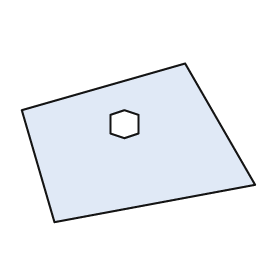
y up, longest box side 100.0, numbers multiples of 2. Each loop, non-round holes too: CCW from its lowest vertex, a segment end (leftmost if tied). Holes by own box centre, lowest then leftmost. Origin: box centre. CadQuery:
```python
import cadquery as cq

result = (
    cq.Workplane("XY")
    .moveTo(-36.0, -34.0)
    .lineTo(50.0, -18.0)
    .lineTo(20.0, 34.0)
    .lineTo(-50.0, 14.0)
    .close()
    .moveTo(-6.0, 2.0)
    .lineTo(0.0, 4.0)
    .lineTo(0.0, 12.0)
    .lineTo(-6.0, 14.0)
    .lineTo(-12.0, 12.0)
    .lineTo(-12.0, 4.0)
    .close()
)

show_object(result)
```